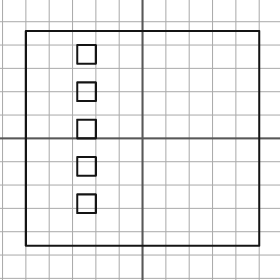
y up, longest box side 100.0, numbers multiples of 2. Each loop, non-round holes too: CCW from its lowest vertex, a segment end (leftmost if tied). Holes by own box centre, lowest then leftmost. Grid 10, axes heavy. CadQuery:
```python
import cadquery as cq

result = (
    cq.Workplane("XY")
    .moveTo(-50.0, -46.0)
    .lineTo(50.0, -46.0)
    .lineTo(50.0, 46.0)
    .lineTo(-50.0, 46.0)
    .close()
    .moveTo(-28.0, -32.0)
    .lineTo(-20.0, -32.0)
    .lineTo(-20.0, -24.0)
    .lineTo(-28.0, -24.0)
    .close()
    .moveTo(-28.0, -16.0)
    .lineTo(-20.0, -16.0)
    .lineTo(-20.0, -8.0)
    .lineTo(-28.0, -8.0)
    .close()
    .moveTo(-28.0, 0.0)
    .lineTo(-20.0, 0.0)
    .lineTo(-20.0, 8.0)
    .lineTo(-28.0, 8.0)
    .close()
    .moveTo(-28.0, 16.0)
    .lineTo(-20.0, 16.0)
    .lineTo(-20.0, 24.0)
    .lineTo(-28.0, 24.0)
    .close()
    .moveTo(-28.0, 32.0)
    .lineTo(-20.0, 32.0)
    .lineTo(-20.0, 40.0)
    .lineTo(-28.0, 40.0)
    .close()
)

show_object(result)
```